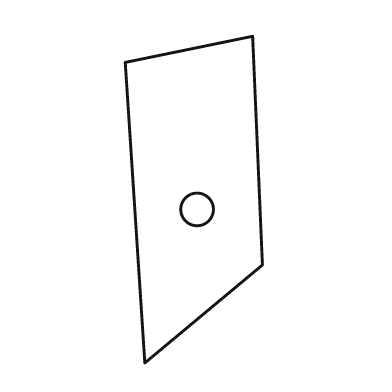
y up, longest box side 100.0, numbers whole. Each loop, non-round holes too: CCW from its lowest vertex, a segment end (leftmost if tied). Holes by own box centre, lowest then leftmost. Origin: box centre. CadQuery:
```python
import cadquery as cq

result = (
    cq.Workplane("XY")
    .moveTo(-15.0, -50.0)
    .lineTo(21.0, -20.0)
    .lineTo(18.0, 50.0)
    .lineTo(-21.0, 42.0)
    .close()
    .moveTo(1.0, -3.0)
    .circle(5.0)
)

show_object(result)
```